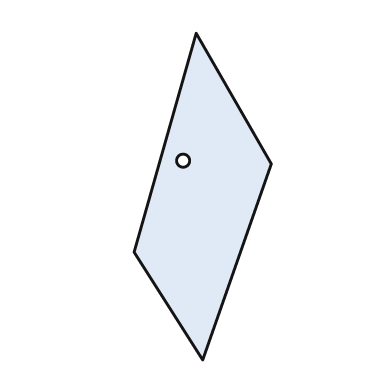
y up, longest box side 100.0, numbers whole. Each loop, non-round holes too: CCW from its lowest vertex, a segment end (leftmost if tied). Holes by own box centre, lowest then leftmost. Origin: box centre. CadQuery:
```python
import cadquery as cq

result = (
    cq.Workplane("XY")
    .moveTo(0.0, -50.0)
    .lineTo(21.0, 10.0)
    .lineTo(-2.0, 50.0)
    .lineTo(-21.0, -17.0)
    .close()
    .moveTo(-6.0, 11.0)
    .circle(2.0)
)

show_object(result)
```